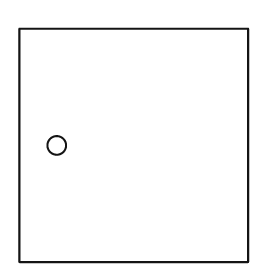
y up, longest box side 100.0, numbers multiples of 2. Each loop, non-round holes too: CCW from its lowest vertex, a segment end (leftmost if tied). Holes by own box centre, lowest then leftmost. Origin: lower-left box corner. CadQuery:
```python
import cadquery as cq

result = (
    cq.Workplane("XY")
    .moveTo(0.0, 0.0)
    .lineTo(98.0, 0.0)
    .lineTo(98.0, 100.0)
    .lineTo(0.0, 100.0)
    .close()
    .moveTo(16.0, 50.0)
    .circle(4.0)
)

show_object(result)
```